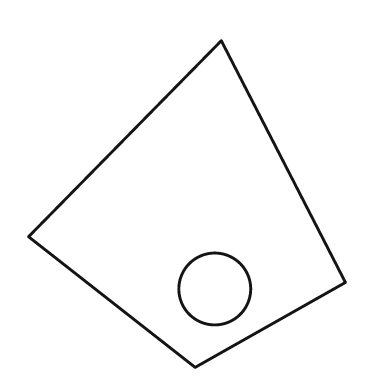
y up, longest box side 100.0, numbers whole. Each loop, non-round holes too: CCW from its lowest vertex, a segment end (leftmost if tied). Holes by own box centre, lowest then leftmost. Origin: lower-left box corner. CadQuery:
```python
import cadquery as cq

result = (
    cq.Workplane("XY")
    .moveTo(51.0, 0.0)
    .lineTo(97.0, 26.0)
    .lineTo(59.0, 100.0)
    .lineTo(0.0, 40.0)
    .close()
    .moveTo(57.0, 24.0)
    .circle(11.0)
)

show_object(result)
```